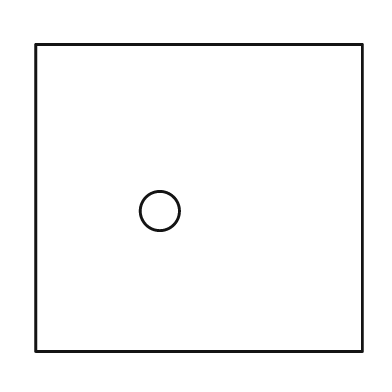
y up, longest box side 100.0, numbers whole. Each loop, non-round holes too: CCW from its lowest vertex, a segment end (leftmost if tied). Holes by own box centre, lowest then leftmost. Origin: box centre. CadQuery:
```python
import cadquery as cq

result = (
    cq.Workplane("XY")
    .moveTo(-50.0, -47.0)
    .lineTo(50.0, -47.0)
    .lineTo(50.0, 47.0)
    .lineTo(-50.0, 47.0)
    .close()
    .moveTo(-12.0, -4.0)
    .circle(6.0)
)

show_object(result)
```